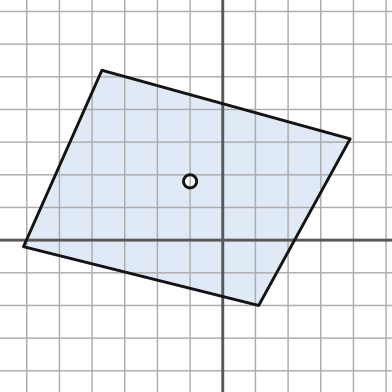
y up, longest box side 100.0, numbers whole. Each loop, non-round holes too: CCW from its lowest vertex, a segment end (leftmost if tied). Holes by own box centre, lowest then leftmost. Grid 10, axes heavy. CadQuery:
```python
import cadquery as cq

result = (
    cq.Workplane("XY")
    .moveTo(11.0, -20.0)
    .lineTo(39.0, 31.0)
    .lineTo(-37.0, 52.0)
    .lineTo(-61.0, -2.0)
    .close()
    .moveTo(-10.0, 18.0)
    .circle(2.0)
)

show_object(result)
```